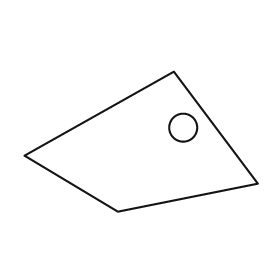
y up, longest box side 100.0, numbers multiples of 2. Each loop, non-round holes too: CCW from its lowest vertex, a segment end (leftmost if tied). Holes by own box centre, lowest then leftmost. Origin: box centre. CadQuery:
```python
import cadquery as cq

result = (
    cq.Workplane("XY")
    .moveTo(-10.0, -30.0)
    .lineTo(50.0, -18.0)
    .lineTo(14.0, 30.0)
    .lineTo(-50.0, -6.0)
    .close()
    .moveTo(18.0, 6.0)
    .circle(6.0)
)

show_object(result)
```